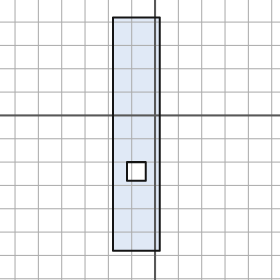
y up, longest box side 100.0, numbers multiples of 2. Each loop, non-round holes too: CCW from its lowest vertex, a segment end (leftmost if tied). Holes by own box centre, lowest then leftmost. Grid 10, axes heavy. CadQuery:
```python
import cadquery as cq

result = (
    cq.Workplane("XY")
    .moveTo(-18.0, -58.0)
    .lineTo(2.0, -58.0)
    .lineTo(2.0, 42.0)
    .lineTo(-18.0, 42.0)
    .close()
    .moveTo(-12.0, -28.0)
    .lineTo(-4.0, -28.0)
    .lineTo(-4.0, -20.0)
    .lineTo(-12.0, -20.0)
    .close()
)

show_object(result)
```